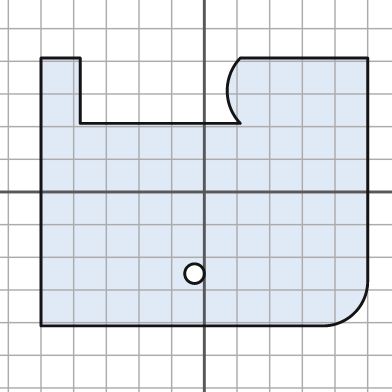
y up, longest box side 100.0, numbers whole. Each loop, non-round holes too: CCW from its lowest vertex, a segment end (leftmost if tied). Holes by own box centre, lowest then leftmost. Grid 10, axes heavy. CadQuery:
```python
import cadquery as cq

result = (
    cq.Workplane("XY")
    .moveTo(-50.0, -41.0)
    .lineTo(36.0, -41.0)
    .threePointArc((46.0, -37.0), (50.0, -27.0))
    .lineTo(50.0, 41.0)
    .lineTo(11.0, 41.0)
    .threePointArc((7.0, 31.0), (11.0, 21.0))
    .lineTo(-38.0, 21.0)
    .lineTo(-38.0, 41.0)
    .lineTo(-50.0, 41.0)
    .close()
    .moveTo(-3.0, -25.0)
    .circle(3.0)
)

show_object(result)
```